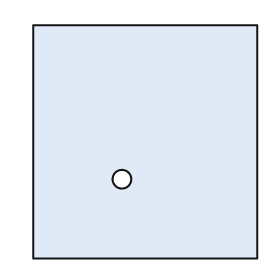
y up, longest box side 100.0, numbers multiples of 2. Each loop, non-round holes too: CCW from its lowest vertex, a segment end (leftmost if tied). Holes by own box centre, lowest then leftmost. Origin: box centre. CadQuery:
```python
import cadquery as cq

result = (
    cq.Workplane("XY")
    .moveTo(-48.0, -50.0)
    .lineTo(48.0, -50.0)
    .lineTo(48.0, 50.0)
    .lineTo(-48.0, 50.0)
    .close()
    .moveTo(-10.0, -16.0)
    .circle(4.0)
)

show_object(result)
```